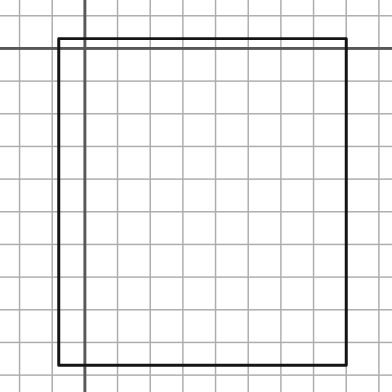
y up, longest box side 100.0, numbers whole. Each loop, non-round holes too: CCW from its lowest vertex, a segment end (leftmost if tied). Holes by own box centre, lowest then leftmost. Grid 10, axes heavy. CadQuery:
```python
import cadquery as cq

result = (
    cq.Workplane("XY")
    .moveTo(-8.0, -97.0)
    .lineTo(80.0, -97.0)
    .lineTo(80.0, 3.0)
    .lineTo(-8.0, 3.0)
    .close()
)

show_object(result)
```